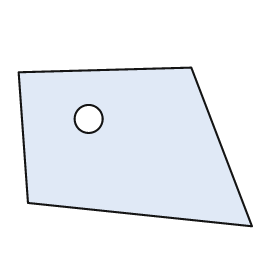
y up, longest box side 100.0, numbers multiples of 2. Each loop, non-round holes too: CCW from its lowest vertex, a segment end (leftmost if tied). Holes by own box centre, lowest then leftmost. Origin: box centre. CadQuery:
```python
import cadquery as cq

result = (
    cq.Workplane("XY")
    .moveTo(50.0, -34.0)
    .lineTo(24.0, 34.0)
    .lineTo(-50.0, 32.0)
    .lineTo(-46.0, -24.0)
    .close()
    .moveTo(-20.0, 12.0)
    .circle(6.0)
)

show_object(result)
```